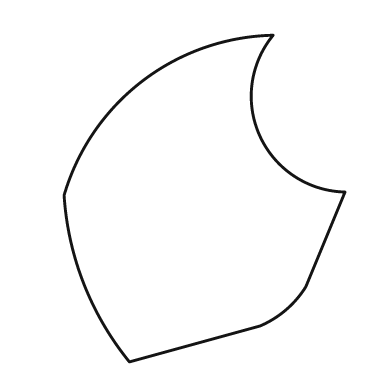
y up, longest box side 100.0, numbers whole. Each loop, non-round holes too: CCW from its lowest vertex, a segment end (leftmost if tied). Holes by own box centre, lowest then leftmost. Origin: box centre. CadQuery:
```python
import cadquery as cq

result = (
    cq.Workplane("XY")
    .moveTo(-23.0, -50.0)
    .lineTo(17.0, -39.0)
    .threePointArc((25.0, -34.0), (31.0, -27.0))
    .lineTo(43.0, 2.0)
    .threePointArc((17.0, 19.0), (21.0, 50.0))
    .threePointArc((-19.0, 36.0), (-43.0, 1.0))
    .threePointArc((-37.0, -26.0), (-23.0, -50.0))
    .close()
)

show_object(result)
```